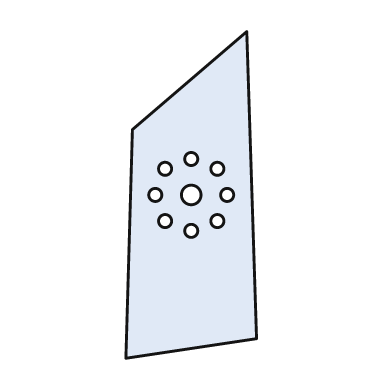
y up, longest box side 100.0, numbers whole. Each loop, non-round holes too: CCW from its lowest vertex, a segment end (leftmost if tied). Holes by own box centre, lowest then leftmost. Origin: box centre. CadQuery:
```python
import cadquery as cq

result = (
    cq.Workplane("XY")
    .moveTo(-20.0, -50.0)
    .lineTo(20.0, -44.0)
    .lineTo(17.0, 50.0)
    .lineTo(-18.0, 20.0)
    .close()
    .moveTo(0.0, -11.0)
    .circle(2.0)
    .moveTo(-8.0, -8.0)
    .circle(2.0)
    .moveTo(8.0, -8.0)
    .circle(2.0)
    .moveTo(-11.0, 0.0)
    .circle(2.0)
    .moveTo(0.0, 0.0)
    .circle(3.0)
    .moveTo(11.0, 0.0)
    .circle(2.0)
    .moveTo(-8.0, 8.0)
    .circle(2.0)
    .moveTo(8.0, 8.0)
    .circle(2.0)
    .moveTo(0.0, 11.0)
    .circle(2.0)
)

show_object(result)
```